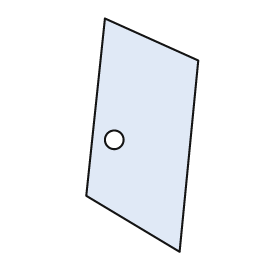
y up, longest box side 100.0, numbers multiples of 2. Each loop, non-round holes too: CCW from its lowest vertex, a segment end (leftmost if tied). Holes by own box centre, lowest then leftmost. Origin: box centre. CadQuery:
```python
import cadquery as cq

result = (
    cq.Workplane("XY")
    .moveTo(16.0, -50.0)
    .lineTo(24.0, 32.0)
    .lineTo(-16.0, 50.0)
    .lineTo(-24.0, -26.0)
    .close()
    .moveTo(-12.0, -2.0)
    .circle(4.0)
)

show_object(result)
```